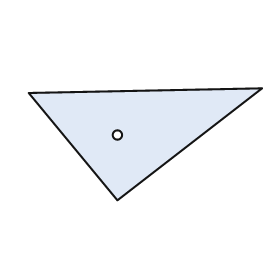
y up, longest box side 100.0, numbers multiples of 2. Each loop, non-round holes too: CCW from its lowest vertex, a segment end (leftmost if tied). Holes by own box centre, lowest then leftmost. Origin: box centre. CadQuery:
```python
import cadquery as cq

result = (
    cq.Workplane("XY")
    .moveTo(-12.0, -24.0)
    .lineTo(50.0, 24.0)
    .lineTo(-50.0, 22.0)
    .close()
    .moveTo(-12.0, 4.0)
    .circle(2.0)
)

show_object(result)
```